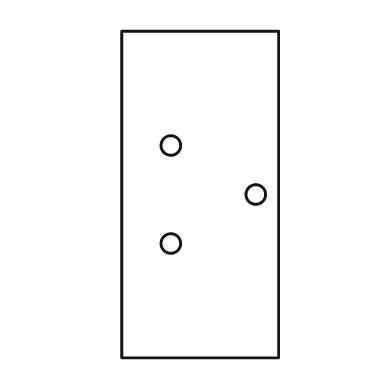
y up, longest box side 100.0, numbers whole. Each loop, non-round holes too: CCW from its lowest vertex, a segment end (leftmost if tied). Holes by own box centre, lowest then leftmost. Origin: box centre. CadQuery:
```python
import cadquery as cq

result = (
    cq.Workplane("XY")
    .moveTo(-24.0, -50.0)
    .lineTo(24.0, -50.0)
    .lineTo(24.0, 50.0)
    .lineTo(-24.0, 50.0)
    .close()
    .moveTo(-9.0, -15.0)
    .circle(3.0)
    .moveTo(17.0, 0.0)
    .circle(3.0)
    .moveTo(-9.0, 15.0)
    .circle(3.0)
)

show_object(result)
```